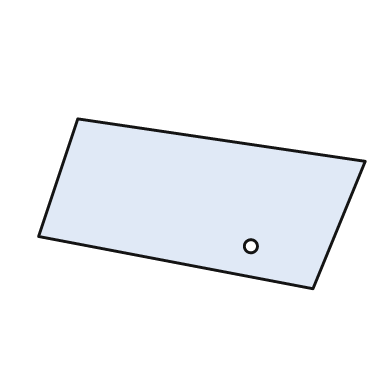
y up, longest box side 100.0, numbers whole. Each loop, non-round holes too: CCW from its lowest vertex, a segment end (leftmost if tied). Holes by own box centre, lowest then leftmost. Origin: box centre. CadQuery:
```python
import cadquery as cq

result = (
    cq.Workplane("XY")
    .moveTo(34.0, -26.0)
    .lineTo(50.0, 13.0)
    .lineTo(-38.0, 26.0)
    .lineTo(-50.0, -10.0)
    .close()
    .moveTo(15.0, -13.0)
    .circle(2.0)
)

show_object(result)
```